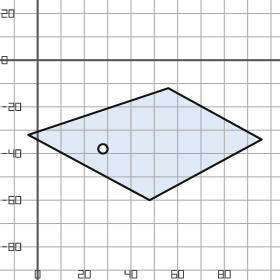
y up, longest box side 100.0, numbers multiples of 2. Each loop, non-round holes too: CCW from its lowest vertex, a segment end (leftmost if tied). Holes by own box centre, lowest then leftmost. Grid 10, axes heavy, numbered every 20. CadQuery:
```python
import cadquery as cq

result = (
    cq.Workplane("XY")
    .moveTo(48.0, -60.0)
    .lineTo(96.0, -34.0)
    .lineTo(56.0, -12.0)
    .lineTo(-4.0, -32.0)
    .close()
    .moveTo(28.0, -38.0)
    .circle(2.0)
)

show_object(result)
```